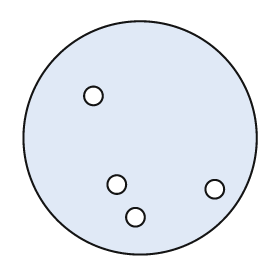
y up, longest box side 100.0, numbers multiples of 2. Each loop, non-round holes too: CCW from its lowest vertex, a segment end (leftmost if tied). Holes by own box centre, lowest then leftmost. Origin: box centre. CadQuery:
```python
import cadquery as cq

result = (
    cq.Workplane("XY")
    .moveTo(0.0, 0.0)
    .circle(50.0)
    .moveTo(-2.0, -34.0)
    .circle(4.0)
    .moveTo(32.0, -22.0)
    .circle(4.0)
    .moveTo(-10.0, -20.0)
    .circle(4.0)
    .moveTo(-20.0, 18.0)
    .circle(4.0)
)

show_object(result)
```